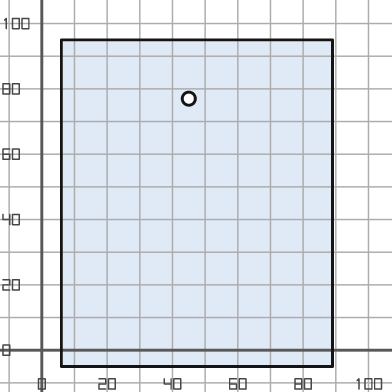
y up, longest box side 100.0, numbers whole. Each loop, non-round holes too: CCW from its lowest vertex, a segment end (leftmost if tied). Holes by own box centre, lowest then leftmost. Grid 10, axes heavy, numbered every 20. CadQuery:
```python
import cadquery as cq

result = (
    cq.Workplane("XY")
    .moveTo(6.0, -5.0)
    .lineTo(89.0, -5.0)
    .lineTo(89.0, 95.0)
    .lineTo(6.0, 95.0)
    .close()
    .moveTo(45.0, 77.0)
    .circle(2.0)
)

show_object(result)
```